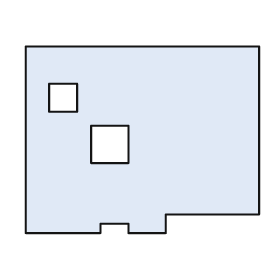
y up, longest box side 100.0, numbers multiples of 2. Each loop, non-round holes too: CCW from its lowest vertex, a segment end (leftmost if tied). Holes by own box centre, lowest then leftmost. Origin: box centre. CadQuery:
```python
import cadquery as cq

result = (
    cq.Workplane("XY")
    .moveTo(-50.0, -40.0)
    .lineTo(-18.0, -40.0)
    .lineTo(-18.0, -36.0)
    .lineTo(-6.0, -36.0)
    .lineTo(-6.0, -40.0)
    .lineTo(10.0, -40.0)
    .lineTo(10.0, -32.0)
    .lineTo(50.0, -32.0)
    .lineTo(50.0, 40.0)
    .lineTo(-50.0, 40.0)
    .close()
    .moveTo(-22.0, -10.0)
    .lineTo(-6.0, -10.0)
    .lineTo(-6.0, 6.0)
    .lineTo(-22.0, 6.0)
    .close()
    .moveTo(-40.0, 12.0)
    .lineTo(-28.0, 12.0)
    .lineTo(-28.0, 24.0)
    .lineTo(-40.0, 24.0)
    .close()
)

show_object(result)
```